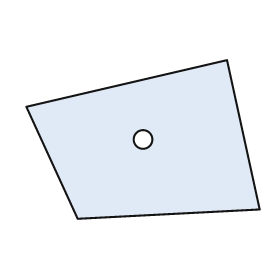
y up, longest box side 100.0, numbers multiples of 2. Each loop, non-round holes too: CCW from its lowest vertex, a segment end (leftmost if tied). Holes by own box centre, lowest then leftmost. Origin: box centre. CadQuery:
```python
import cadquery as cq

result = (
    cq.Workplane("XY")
    .moveTo(-28.0, -34.0)
    .lineTo(50.0, -30.0)
    .lineTo(36.0, 34.0)
    .lineTo(-50.0, 14.0)
    .close()
    .moveTo(0.0, 0.0)
    .circle(4.0)
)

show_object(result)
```